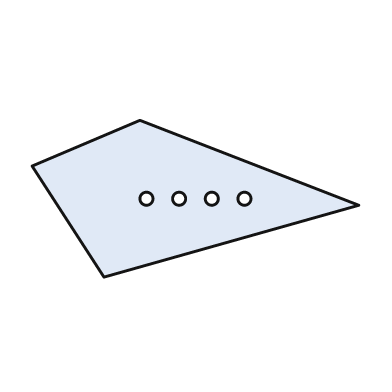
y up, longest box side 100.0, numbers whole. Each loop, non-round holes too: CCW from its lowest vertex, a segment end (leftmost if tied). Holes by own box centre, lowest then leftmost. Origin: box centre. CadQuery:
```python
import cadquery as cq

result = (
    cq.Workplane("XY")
    .moveTo(-28.0, -24.0)
    .lineTo(50.0, -2.0)
    .lineTo(-17.0, 24.0)
    .lineTo(-50.0, 10.0)
    .close()
    .moveTo(-15.0, 0.0)
    .circle(2.0)
    .moveTo(-5.0, 0.0)
    .circle(2.0)
    .moveTo(5.0, 0.0)
    .circle(2.0)
    .moveTo(15.0, 0.0)
    .circle(2.0)
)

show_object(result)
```